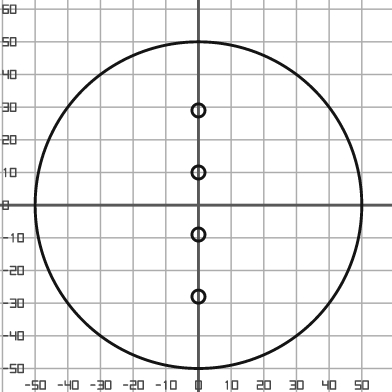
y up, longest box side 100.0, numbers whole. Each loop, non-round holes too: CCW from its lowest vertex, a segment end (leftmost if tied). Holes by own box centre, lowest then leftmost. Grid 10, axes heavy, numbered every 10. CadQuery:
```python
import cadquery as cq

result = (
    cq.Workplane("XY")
    .moveTo(0.0, 0.0)
    .circle(50.0)
    .moveTo(0.0, -28.0)
    .circle(2.0)
    .moveTo(0.0, -9.0)
    .circle(2.0)
    .moveTo(0.0, 10.0)
    .circle(2.0)
    .moveTo(0.0, 29.0)
    .circle(2.0)
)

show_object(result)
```